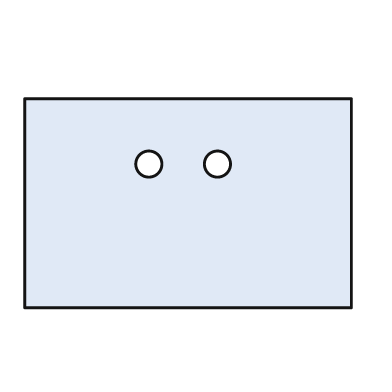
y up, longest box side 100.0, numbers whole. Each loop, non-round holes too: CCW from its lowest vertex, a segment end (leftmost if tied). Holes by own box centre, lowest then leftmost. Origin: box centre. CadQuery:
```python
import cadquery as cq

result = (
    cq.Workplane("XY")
    .moveTo(-50.0, -32.0)
    .lineTo(50.0, -32.0)
    .lineTo(50.0, 32.0)
    .lineTo(-50.0, 32.0)
    .close()
    .moveTo(-12.0, 12.0)
    .circle(4.0)
    .moveTo(9.0, 12.0)
    .circle(4.0)
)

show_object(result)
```